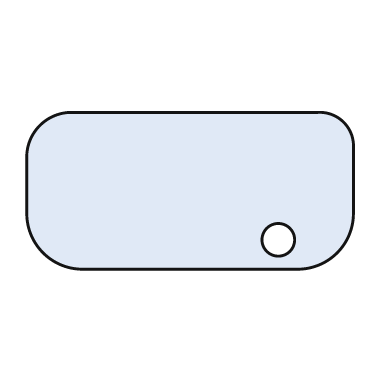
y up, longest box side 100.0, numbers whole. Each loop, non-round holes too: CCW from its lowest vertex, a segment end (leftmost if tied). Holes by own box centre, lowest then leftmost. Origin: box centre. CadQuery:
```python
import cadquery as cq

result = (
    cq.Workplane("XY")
    .moveTo(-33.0, -24.0)
    .lineTo(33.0, -24.0)
    .threePointArc((45.0, -19.0), (50.0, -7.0))
    .lineTo(50.0, 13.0)
    .threePointArc((47.0, 21.0), (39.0, 24.0))
    .lineTo(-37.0, 24.0)
    .threePointArc((-46.0, 20.0), (-50.0, 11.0))
    .lineTo(-50.0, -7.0)
    .threePointArc((-45.0, -19.0), (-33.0, -24.0))
    .close()
    .moveTo(27.0, -15.0)
    .circle(5.0)
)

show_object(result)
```